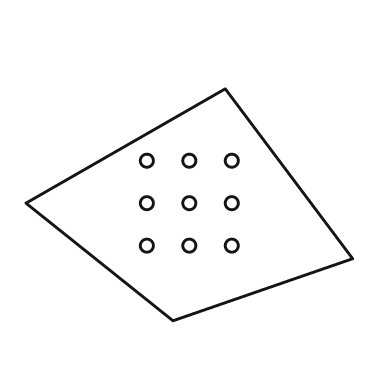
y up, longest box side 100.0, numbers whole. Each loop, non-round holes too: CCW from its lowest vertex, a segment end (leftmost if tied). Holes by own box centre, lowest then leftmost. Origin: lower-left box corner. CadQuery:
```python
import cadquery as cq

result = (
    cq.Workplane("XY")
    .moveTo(45.0, 0.0)
    .lineTo(100.0, 19.0)
    .lineTo(61.0, 71.0)
    .lineTo(0.0, 36.0)
    .close()
    .moveTo(37.0, 23.0)
    .circle(2.0)
    .moveTo(50.0, 23.0)
    .circle(2.0)
    .moveTo(63.0, 23.0)
    .circle(2.0)
    .moveTo(37.0, 36.0)
    .circle(2.0)
    .moveTo(50.0, 36.0)
    .circle(2.0)
    .moveTo(63.0, 36.0)
    .circle(2.0)
    .moveTo(37.0, 49.0)
    .circle(2.0)
    .moveTo(50.0, 49.0)
    .circle(2.0)
    .moveTo(63.0, 49.0)
    .circle(2.0)
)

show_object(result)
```